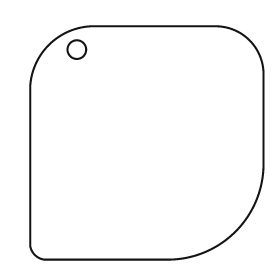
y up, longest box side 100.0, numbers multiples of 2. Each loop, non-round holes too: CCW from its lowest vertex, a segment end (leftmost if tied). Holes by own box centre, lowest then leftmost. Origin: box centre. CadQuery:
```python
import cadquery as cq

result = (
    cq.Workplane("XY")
    .moveTo(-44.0, -50.0)
    .lineTo(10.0, -50.0)
    .threePointArc((38.0, -38.0), (50.0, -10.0))
    .lineTo(50.0, 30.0)
    .threePointArc((44.0, 44.0), (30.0, 50.0))
    .lineTo(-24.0, 50.0)
    .threePointArc((-42.0, 42.0), (-50.0, 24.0))
    .lineTo(-50.0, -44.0)
    .threePointArc((-48.0, -48.0), (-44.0, -50.0))
    .close()
    .moveTo(-30.0, 40.0)
    .circle(4.0)
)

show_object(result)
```